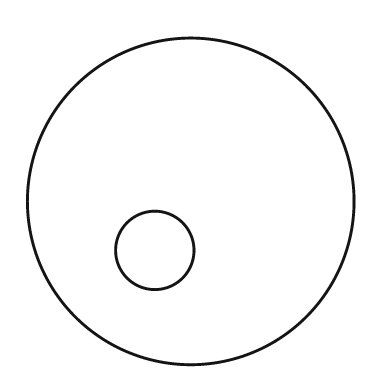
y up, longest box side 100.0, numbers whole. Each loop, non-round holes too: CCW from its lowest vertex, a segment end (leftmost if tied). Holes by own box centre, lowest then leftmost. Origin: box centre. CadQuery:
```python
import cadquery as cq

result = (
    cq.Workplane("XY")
    .moveTo(0.0, 0.0)
    .circle(50.0)
    .moveTo(-11.0, -15.0)
    .circle(12.0)
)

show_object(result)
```